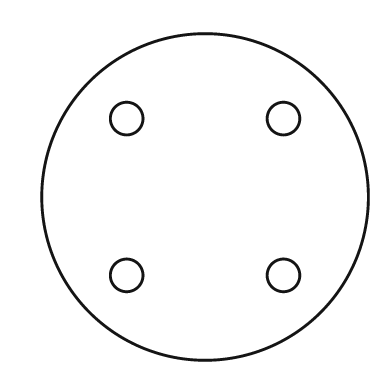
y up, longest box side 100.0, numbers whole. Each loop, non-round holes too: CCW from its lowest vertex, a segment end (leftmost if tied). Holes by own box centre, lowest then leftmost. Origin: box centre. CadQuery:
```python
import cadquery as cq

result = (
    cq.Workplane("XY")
    .moveTo(0.0, 0.0)
    .circle(50.0)
    .moveTo(-24.0, -24.0)
    .circle(5.0)
    .moveTo(24.0, -24.0)
    .circle(5.0)
    .moveTo(-24.0, 24.0)
    .circle(5.0)
    .moveTo(24.0, 24.0)
    .circle(5.0)
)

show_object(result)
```